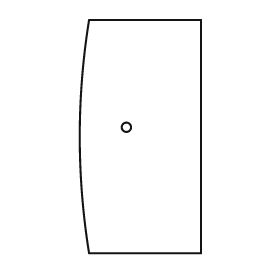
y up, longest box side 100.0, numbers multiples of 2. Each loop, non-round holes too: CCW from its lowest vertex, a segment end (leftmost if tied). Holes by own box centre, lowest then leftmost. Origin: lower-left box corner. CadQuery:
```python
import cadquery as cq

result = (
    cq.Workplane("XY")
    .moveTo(4.0, 0.0)
    .lineTo(52.0, 0.0)
    .lineTo(52.0, 100.0)
    .lineTo(4.0, 100.0)
    .threePointArc((0.0, 50.0), (4.0, 0.0))
    .close()
    .moveTo(20.0, 54.0)
    .circle(2.0)
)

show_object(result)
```